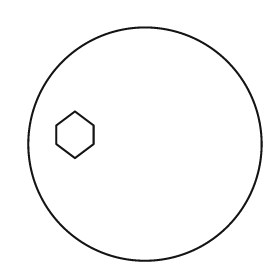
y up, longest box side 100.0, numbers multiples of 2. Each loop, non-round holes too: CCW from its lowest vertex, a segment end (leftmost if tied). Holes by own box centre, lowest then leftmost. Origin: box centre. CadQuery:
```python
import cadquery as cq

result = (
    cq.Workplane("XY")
    .moveTo(0.0, 0.0)
    .circle(50.0)
    .moveTo(-30.0, -6.0)
    .lineTo(-22.0, 0.0)
    .lineTo(-22.0, 8.0)
    .lineTo(-30.0, 14.0)
    .lineTo(-38.0, 8.0)
    .lineTo(-38.0, 0.0)
    .close()
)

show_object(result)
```